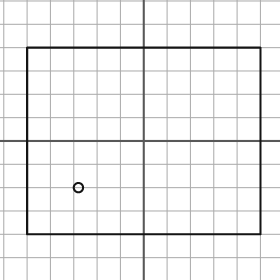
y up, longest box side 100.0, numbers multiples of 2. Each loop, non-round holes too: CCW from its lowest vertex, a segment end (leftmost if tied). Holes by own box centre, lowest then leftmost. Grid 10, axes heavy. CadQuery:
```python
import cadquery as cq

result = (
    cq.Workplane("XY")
    .moveTo(-50.0, -40.0)
    .lineTo(50.0, -40.0)
    .lineTo(50.0, 40.0)
    .lineTo(-50.0, 40.0)
    .close()
    .moveTo(-28.0, -20.0)
    .circle(2.0)
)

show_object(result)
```